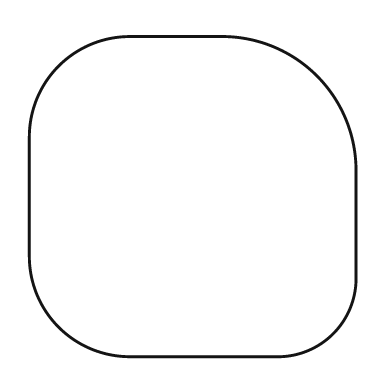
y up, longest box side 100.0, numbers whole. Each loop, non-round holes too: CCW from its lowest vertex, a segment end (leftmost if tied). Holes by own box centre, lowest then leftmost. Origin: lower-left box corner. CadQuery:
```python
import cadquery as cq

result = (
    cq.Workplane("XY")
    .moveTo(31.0, 0.0)
    .lineTo(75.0, 0.0)
    .threePointArc((93.0, 7.0), (100.0, 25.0))
    .lineTo(100.0, 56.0)
    .threePointArc((88.0, 86.0), (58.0, 98.0))
    .lineTo(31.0, 98.0)
    .threePointArc((9.0, 89.0), (0.0, 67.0))
    .lineTo(0.0, 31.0)
    .threePointArc((9.0, 9.0), (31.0, 0.0))
    .close()
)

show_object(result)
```